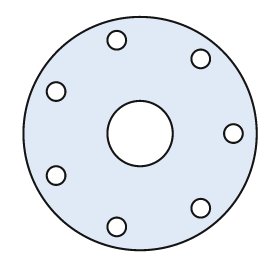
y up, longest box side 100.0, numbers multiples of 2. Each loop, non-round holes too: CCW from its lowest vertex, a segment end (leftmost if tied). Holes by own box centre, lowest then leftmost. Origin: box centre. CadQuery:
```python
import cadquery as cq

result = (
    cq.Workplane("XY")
    .moveTo(0.0, 0.0)
    .circle(50.0)
    .moveTo(-10.0, -40.0)
    .circle(4.0)
    .moveTo(26.0, -32.0)
    .circle(4.0)
    .moveTo(-36.0, -18.0)
    .circle(4.0)
    .moveTo(0.0, 0.0)
    .circle(14.0)
    .moveTo(40.0, 0.0)
    .circle(4.0)
    .moveTo(-36.0, 18.0)
    .circle(4.0)
    .moveTo(26.0, 32.0)
    .circle(4.0)
    .moveTo(-10.0, 40.0)
    .circle(4.0)
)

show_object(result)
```